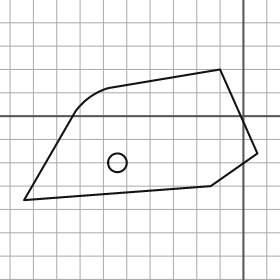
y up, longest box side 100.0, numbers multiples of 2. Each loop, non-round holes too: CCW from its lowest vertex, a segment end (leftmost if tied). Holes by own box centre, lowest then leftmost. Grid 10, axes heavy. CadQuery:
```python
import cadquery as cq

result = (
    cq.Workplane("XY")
    .moveTo(-94.0, -36.0)
    .lineTo(-14.0, -30.0)
    .lineTo(6.0, -16.0)
    .lineTo(-10.0, 20.0)
    .lineTo(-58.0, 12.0)
    .threePointArc((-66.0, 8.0), (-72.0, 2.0))
    .close()
    .moveTo(-54.0, -20.0)
    .circle(4.0)
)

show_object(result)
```